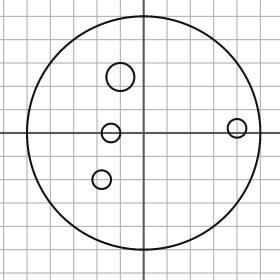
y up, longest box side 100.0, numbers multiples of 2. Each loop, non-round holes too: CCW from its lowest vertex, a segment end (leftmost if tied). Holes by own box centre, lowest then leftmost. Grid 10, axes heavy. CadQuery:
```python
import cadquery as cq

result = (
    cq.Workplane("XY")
    .moveTo(0.0, 0.0)
    .circle(50.0)
    .moveTo(-18.0, -20.0)
    .circle(4.0)
    .moveTo(-14.0, 0.0)
    .circle(4.0)
    .moveTo(40.0, 2.0)
    .circle(4.0)
    .moveTo(-10.0, 24.0)
    .circle(6.0)
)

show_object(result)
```